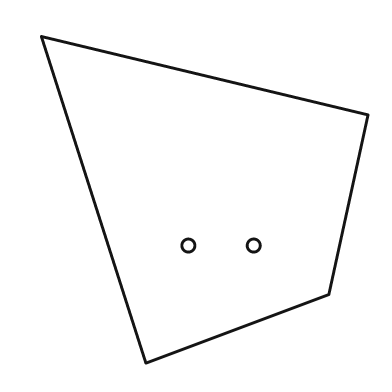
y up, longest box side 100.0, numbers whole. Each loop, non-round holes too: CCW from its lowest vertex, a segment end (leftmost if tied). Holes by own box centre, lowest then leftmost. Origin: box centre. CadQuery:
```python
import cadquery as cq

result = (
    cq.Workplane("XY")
    .moveTo(-18.0, -50.0)
    .lineTo(38.0, -29.0)
    .lineTo(50.0, 26.0)
    .lineTo(-50.0, 50.0)
    .close()
    .moveTo(-5.0, -14.0)
    .circle(2.0)
    .moveTo(15.0, -14.0)
    .circle(2.0)
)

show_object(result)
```